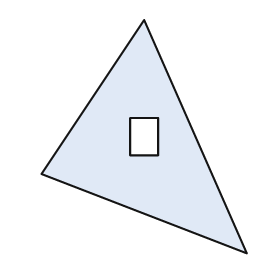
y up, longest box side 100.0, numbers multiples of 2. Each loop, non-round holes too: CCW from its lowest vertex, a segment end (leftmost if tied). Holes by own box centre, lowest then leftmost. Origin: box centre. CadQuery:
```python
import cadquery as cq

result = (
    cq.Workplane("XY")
    .moveTo(44.0, -50.0)
    .lineTo(0.0, 50.0)
    .lineTo(-44.0, -16.0)
    .close()
    .moveTo(-6.0, -8.0)
    .lineTo(6.0, -8.0)
    .lineTo(6.0, 8.0)
    .lineTo(-6.0, 8.0)
    .close()
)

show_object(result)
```